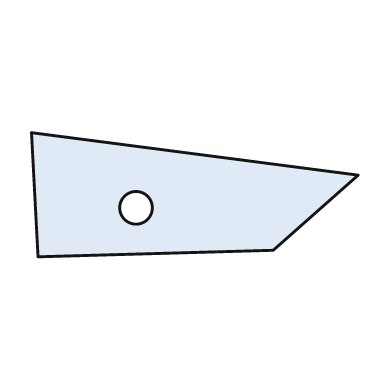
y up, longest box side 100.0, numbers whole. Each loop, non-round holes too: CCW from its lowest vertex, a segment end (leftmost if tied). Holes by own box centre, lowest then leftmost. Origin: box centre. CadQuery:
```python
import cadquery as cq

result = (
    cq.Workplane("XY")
    .moveTo(-48.0, -19.0)
    .lineTo(24.0, -17.0)
    .lineTo(50.0, 6.0)
    .lineTo(-50.0, 19.0)
    .close()
    .moveTo(-18.0, -4.0)
    .circle(5.0)
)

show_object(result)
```